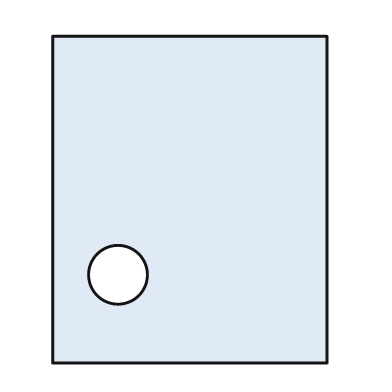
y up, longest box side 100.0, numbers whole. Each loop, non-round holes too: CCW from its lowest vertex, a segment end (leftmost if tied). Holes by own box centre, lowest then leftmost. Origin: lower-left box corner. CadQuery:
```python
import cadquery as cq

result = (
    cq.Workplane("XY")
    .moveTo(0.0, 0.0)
    .lineTo(84.0, 0.0)
    .lineTo(84.0, 100.0)
    .lineTo(0.0, 100.0)
    .close()
    .moveTo(20.0, 27.0)
    .circle(9.0)
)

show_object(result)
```